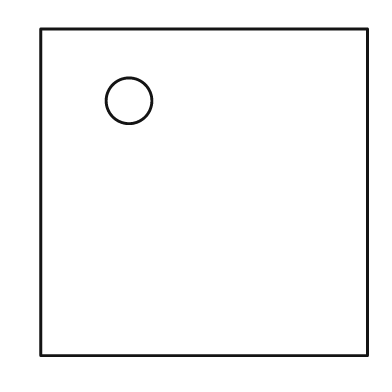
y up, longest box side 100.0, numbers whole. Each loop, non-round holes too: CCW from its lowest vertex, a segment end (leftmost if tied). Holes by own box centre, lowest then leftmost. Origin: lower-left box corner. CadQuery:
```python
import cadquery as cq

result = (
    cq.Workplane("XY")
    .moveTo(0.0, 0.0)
    .lineTo(100.0, 0.0)
    .lineTo(100.0, 100.0)
    .lineTo(0.0, 100.0)
    .close()
    .moveTo(27.0, 78.0)
    .circle(7.0)
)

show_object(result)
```